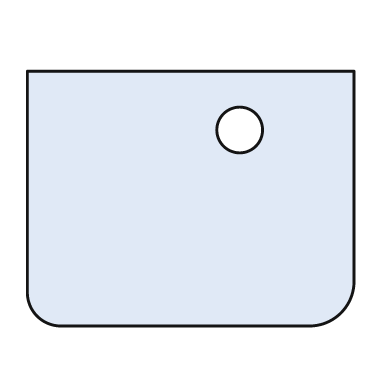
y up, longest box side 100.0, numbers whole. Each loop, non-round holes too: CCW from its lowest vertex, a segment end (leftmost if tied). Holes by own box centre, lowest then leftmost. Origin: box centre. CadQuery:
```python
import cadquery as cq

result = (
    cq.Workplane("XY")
    .moveTo(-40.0, -39.0)
    .lineTo(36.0, -39.0)
    .threePointArc((46.0, -35.0), (50.0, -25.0))
    .lineTo(50.0, 39.0)
    .lineTo(-50.0, 39.0)
    .lineTo(-50.0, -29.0)
    .threePointArc((-47.0, -36.0), (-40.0, -39.0))
    .close()
    .moveTo(15.0, 21.0)
    .circle(7.0)
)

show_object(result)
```